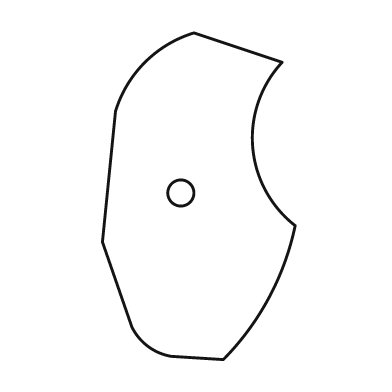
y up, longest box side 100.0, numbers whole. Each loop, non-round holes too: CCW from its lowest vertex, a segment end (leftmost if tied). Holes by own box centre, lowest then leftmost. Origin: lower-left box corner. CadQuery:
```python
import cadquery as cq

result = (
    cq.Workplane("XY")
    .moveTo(37.0, 0.0)
    .threePointArc((51.0, 19.0), (59.0, 41.0))
    .threePointArc((46.0, 65.0), (55.0, 91.0))
    .lineTo(28.0, 100.0)
    .threePointArc((13.0, 91.0), (4.0, 76.0))
    .lineTo(0.0, 36.0)
    .lineTo(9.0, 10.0)
    .threePointArc((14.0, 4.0), (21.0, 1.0))
    .close()
    .moveTo(24.0, 51.0)
    .circle(4.0)
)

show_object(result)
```